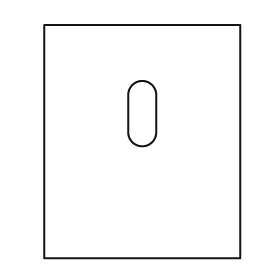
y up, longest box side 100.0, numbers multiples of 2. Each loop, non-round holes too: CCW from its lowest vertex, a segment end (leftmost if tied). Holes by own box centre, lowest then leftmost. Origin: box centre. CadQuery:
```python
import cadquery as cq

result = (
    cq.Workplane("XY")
    .moveTo(-42.0, -50.0)
    .lineTo(42.0, -50.0)
    .lineTo(42.0, 50.0)
    .lineTo(-42.0, 50.0)
    .close()
    .moveTo(-6.0, 4.0)
    .threePointArc((0.0, -2.0), (6.0, 4.0))
    .lineTo(6.0, 20.0)
    .threePointArc((0.0, 26.0), (-6.0, 20.0))
    .close()
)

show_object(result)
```